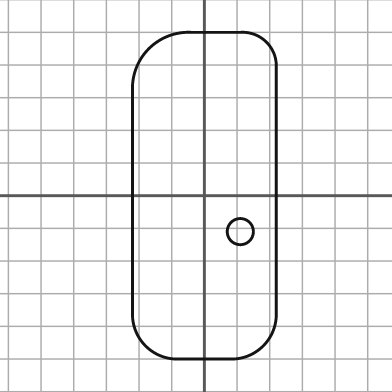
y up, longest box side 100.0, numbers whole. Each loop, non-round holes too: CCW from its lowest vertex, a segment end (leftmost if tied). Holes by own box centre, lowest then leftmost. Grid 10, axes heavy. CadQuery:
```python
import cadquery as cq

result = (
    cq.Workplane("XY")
    .moveTo(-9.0, -50.0)
    .lineTo(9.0, -50.0)
    .threePointArc((18.0, -46.0), (22.0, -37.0))
    .lineTo(22.0, 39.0)
    .threePointArc((19.0, 47.0), (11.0, 50.0))
    .lineTo(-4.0, 50.0)
    .threePointArc((-17.0, 45.0), (-22.0, 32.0))
    .lineTo(-22.0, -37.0)
    .threePointArc((-18.0, -46.0), (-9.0, -50.0))
    .close()
    .moveTo(11.0, -11.0)
    .circle(4.0)
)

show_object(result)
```